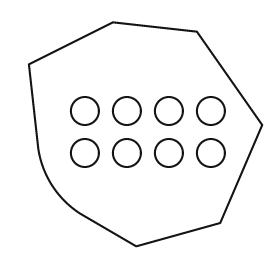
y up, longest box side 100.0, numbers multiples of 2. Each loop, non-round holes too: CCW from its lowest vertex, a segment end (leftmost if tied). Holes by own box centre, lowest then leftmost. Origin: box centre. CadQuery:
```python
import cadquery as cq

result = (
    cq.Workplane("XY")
    .moveTo(-4.0, -48.0)
    .lineTo(32.0, -38.0)
    .lineTo(50.0, 4.0)
    .lineTo(22.0, 44.0)
    .lineTo(-14.0, 48.0)
    .lineTo(-50.0, 30.0)
    .lineTo(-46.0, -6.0)
    .threePointArc((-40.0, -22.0), (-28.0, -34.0))
    .close()
    .moveTo(-26.0, -8.0)
    .circle(6.0)
    .moveTo(-8.0, -8.0)
    .circle(6.0)
    .moveTo(10.0, -8.0)
    .circle(6.0)
    .moveTo(28.0, -8.0)
    .circle(6.0)
    .moveTo(-26.0, 10.0)
    .circle(6.0)
    .moveTo(-8.0, 10.0)
    .circle(6.0)
    .moveTo(10.0, 10.0)
    .circle(6.0)
    .moveTo(28.0, 10.0)
    .circle(6.0)
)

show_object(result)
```